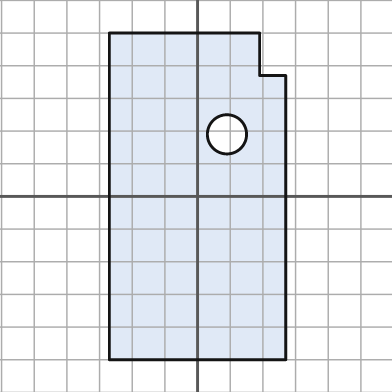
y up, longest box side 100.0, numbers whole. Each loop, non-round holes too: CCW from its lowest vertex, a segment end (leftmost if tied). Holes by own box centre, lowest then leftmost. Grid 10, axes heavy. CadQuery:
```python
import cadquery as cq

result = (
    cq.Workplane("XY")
    .moveTo(-27.0, -50.0)
    .lineTo(27.0, -50.0)
    .lineTo(27.0, 37.0)
    .lineTo(19.0, 37.0)
    .lineTo(19.0, 50.0)
    .lineTo(-27.0, 50.0)
    .close()
    .moveTo(9.0, 19.0)
    .circle(6.0)
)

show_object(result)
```